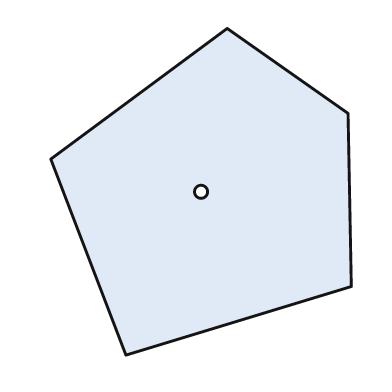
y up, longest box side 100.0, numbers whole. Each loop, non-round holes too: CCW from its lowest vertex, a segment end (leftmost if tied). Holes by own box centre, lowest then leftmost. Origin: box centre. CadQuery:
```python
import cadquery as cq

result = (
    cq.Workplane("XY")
    .moveTo(-23.0, -50.0)
    .lineTo(46.0, -29.0)
    .lineTo(45.0, 24.0)
    .lineTo(8.0, 50.0)
    .lineTo(-46.0, 10.0)
    .close()
    .moveTo(0.0, 0.0)
    .circle(2.0)
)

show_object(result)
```